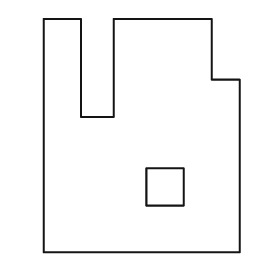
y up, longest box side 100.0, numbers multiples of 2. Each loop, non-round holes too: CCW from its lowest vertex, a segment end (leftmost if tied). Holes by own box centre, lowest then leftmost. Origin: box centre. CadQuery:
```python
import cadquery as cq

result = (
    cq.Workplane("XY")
    .moveTo(-42.0, -50.0)
    .lineTo(42.0, -50.0)
    .lineTo(42.0, 24.0)
    .lineTo(30.0, 24.0)
    .lineTo(30.0, 50.0)
    .lineTo(-12.0, 50.0)
    .lineTo(-12.0, 8.0)
    .lineTo(-26.0, 8.0)
    .lineTo(-26.0, 50.0)
    .lineTo(-42.0, 50.0)
    .close()
    .moveTo(2.0, -30.0)
    .lineTo(18.0, -30.0)
    .lineTo(18.0, -14.0)
    .lineTo(2.0, -14.0)
    .close()
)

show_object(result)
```